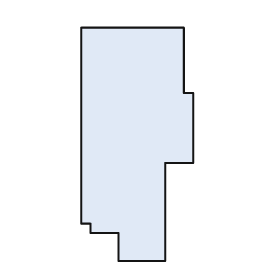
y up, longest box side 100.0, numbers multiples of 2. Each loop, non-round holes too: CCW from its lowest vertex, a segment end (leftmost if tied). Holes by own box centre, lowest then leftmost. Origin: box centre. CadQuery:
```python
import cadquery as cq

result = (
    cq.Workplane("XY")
    .moveTo(-8.0, -50.0)
    .lineTo(12.0, -50.0)
    .lineTo(12.0, -8.0)
    .lineTo(24.0, -8.0)
    .lineTo(24.0, 22.0)
    .lineTo(20.0, 22.0)
    .lineTo(20.0, 50.0)
    .lineTo(-24.0, 50.0)
    .lineTo(-24.0, -34.0)
    .lineTo(-20.0, -34.0)
    .lineTo(-20.0, -38.0)
    .lineTo(-8.0, -38.0)
    .close()
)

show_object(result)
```